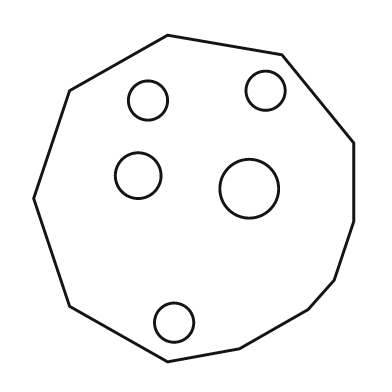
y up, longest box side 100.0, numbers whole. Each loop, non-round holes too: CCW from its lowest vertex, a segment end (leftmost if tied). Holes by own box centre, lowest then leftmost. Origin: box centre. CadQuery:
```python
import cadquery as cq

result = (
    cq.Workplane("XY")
    .moveTo(-8.0, -50.0)
    .lineTo(14.0, -46.0)
    .lineTo(35.0, -34.0)
    .lineTo(43.0, -25.0)
    .lineTo(49.0, -7.0)
    .lineTo(49.0, 17.0)
    .lineTo(27.0, 44.0)
    .lineTo(-8.0, 50.0)
    .lineTo(-38.0, 33.0)
    .lineTo(-49.0, 0.0)
    .lineTo(-38.0, -33.0)
    .close()
    .moveTo(-6.0, -38.0)
    .circle(6.0)
    .moveTo(17.0, 3.0)
    .circle(9.0)
    .moveTo(-17.0, 7.0)
    .circle(7.0)
    .moveTo(-14.0, 30.0)
    .circle(6.0)
    .moveTo(22.0, 33.0)
    .circle(6.0)
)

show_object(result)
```